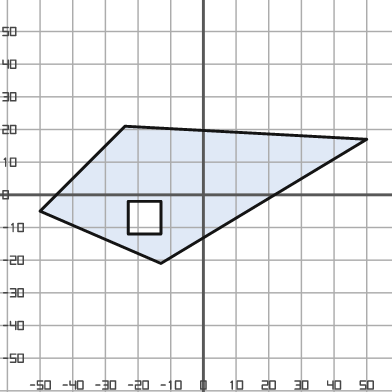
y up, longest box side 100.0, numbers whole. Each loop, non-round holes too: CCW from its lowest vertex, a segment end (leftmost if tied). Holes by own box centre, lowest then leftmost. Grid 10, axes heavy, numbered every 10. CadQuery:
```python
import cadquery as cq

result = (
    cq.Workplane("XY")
    .moveTo(-13.0, -21.0)
    .lineTo(50.0, 17.0)
    .lineTo(-24.0, 21.0)
    .lineTo(-50.0, -5.0)
    .close()
    .moveTo(-23.0, -12.0)
    .lineTo(-13.0, -12.0)
    .lineTo(-13.0, -2.0)
    .lineTo(-23.0, -2.0)
    .close()
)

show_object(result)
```